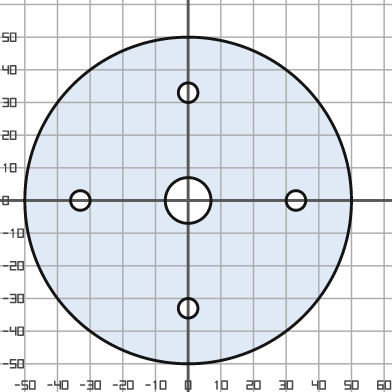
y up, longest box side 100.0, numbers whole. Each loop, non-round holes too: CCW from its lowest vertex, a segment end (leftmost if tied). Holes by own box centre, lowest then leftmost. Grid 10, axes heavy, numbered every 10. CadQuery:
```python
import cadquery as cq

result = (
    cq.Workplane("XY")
    .moveTo(0.0, 0.0)
    .circle(50.0)
    .moveTo(0.0, -33.0)
    .circle(3.0)
    .moveTo(-33.0, 0.0)
    .circle(3.0)
    .moveTo(0.0, 0.0)
    .circle(7.0)
    .moveTo(33.0, 0.0)
    .circle(3.0)
    .moveTo(0.0, 33.0)
    .circle(3.0)
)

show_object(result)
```